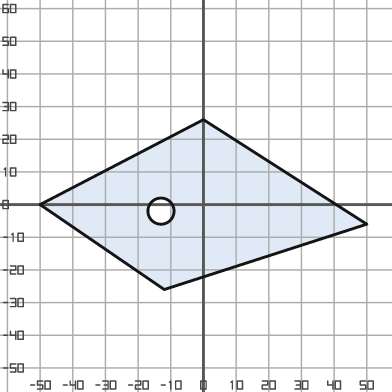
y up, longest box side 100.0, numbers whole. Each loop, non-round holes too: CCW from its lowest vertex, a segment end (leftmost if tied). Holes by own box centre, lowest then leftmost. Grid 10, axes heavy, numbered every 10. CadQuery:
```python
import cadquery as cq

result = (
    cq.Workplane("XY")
    .moveTo(-12.0, -26.0)
    .lineTo(50.0, -6.0)
    .lineTo(0.0, 26.0)
    .lineTo(-50.0, 0.0)
    .close()
    .moveTo(-13.0, -2.0)
    .circle(4.0)
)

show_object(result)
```